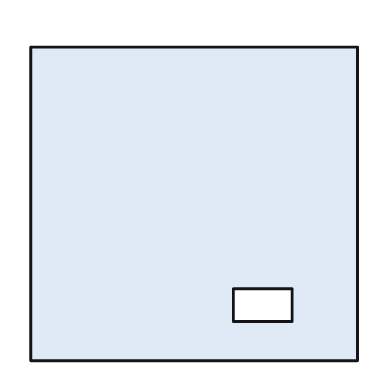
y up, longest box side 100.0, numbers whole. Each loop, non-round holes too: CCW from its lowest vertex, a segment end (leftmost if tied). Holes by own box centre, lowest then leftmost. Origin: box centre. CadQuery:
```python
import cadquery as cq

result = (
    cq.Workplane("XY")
    .moveTo(-50.0, -48.0)
    .lineTo(50.0, -48.0)
    .lineTo(50.0, 48.0)
    .lineTo(-50.0, 48.0)
    .close()
    .moveTo(12.0, -36.0)
    .lineTo(30.0, -36.0)
    .lineTo(30.0, -26.0)
    .lineTo(12.0, -26.0)
    .close()
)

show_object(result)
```